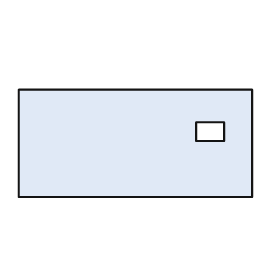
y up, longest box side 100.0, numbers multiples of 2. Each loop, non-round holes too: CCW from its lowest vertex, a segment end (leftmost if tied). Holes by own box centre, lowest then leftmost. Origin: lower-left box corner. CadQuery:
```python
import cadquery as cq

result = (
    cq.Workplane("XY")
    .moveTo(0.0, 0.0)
    .lineTo(100.0, 0.0)
    .lineTo(100.0, 46.0)
    .lineTo(0.0, 46.0)
    .close()
    .moveTo(76.0, 24.0)
    .lineTo(88.0, 24.0)
    .lineTo(88.0, 32.0)
    .lineTo(76.0, 32.0)
    .close()
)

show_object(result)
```